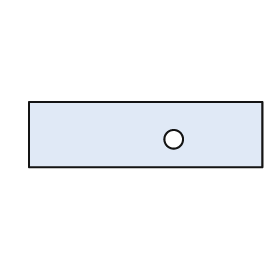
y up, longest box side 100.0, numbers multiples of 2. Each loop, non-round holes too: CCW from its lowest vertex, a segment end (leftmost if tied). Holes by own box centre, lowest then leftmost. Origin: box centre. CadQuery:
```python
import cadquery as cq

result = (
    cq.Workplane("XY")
    .moveTo(-50.0, -14.0)
    .lineTo(50.0, -14.0)
    .lineTo(50.0, 14.0)
    .lineTo(-50.0, 14.0)
    .close()
    .moveTo(12.0, -2.0)
    .circle(4.0)
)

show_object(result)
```